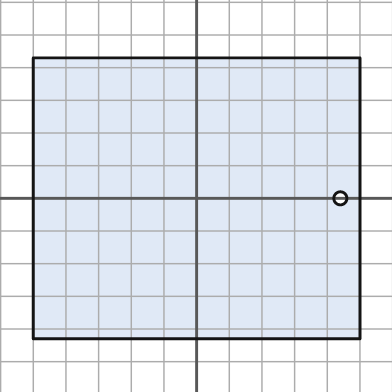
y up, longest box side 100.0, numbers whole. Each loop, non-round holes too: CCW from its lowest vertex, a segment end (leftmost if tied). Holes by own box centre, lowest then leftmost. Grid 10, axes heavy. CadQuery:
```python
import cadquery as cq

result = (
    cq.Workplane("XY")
    .moveTo(-50.0, -43.0)
    .lineTo(50.0, -43.0)
    .lineTo(50.0, 43.0)
    .lineTo(-50.0, 43.0)
    .close()
    .moveTo(44.0, 0.0)
    .circle(2.0)
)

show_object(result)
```